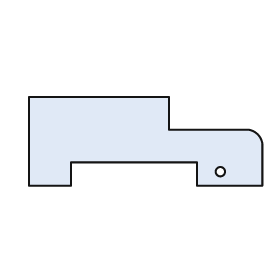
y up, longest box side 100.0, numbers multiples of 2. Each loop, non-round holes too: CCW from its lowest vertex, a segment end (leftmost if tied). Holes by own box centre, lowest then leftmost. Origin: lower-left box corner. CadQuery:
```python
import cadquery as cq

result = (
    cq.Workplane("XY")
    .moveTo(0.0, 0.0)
    .lineTo(18.0, 0.0)
    .lineTo(18.0, 10.0)
    .lineTo(72.0, 10.0)
    .lineTo(72.0, 0.0)
    .lineTo(100.0, 0.0)
    .lineTo(100.0, 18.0)
    .threePointArc((98.0, 22.0), (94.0, 24.0))
    .lineTo(60.0, 24.0)
    .lineTo(60.0, 38.0)
    .lineTo(0.0, 38.0)
    .close()
    .moveTo(82.0, 6.0)
    .circle(2.0)
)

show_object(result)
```